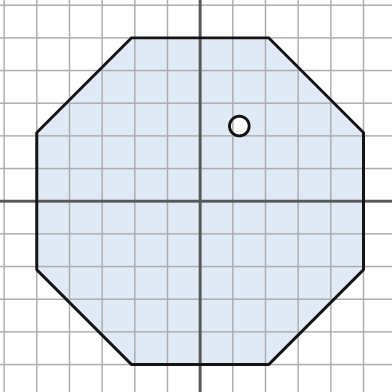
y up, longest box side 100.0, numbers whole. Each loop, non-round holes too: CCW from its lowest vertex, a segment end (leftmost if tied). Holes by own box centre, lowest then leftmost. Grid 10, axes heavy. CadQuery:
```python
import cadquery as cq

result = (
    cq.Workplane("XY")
    .moveTo(-21.0, -50.0)
    .lineTo(21.0, -50.0)
    .lineTo(50.0, -21.0)
    .lineTo(50.0, 21.0)
    .lineTo(21.0, 50.0)
    .lineTo(-21.0, 50.0)
    .lineTo(-50.0, 21.0)
    .lineTo(-50.0, -21.0)
    .close()
    .moveTo(12.0, 23.0)
    .circle(3.0)
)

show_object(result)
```